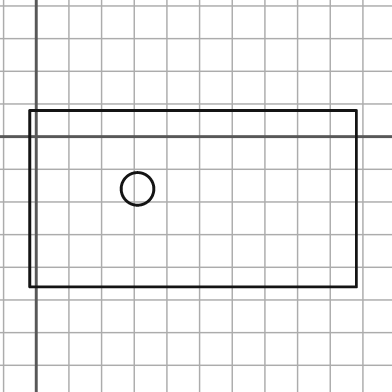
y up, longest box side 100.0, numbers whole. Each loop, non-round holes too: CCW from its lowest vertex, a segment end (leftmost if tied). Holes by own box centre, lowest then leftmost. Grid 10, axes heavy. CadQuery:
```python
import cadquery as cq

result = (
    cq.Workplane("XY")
    .moveTo(-2.0, -46.0)
    .lineTo(98.0, -46.0)
    .lineTo(98.0, 8.0)
    .lineTo(-2.0, 8.0)
    .close()
    .moveTo(31.0, -16.0)
    .circle(5.0)
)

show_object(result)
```